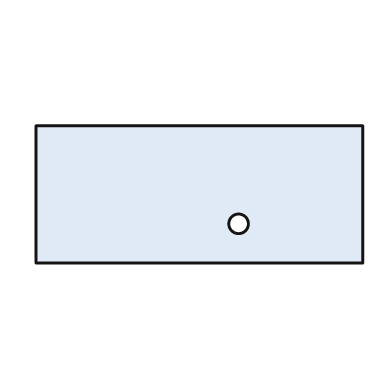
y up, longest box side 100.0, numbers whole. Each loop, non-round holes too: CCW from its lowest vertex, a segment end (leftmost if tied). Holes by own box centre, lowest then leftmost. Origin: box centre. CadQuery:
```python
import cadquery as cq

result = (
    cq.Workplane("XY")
    .moveTo(-50.0, -21.0)
    .lineTo(50.0, -21.0)
    .lineTo(50.0, 21.0)
    .lineTo(-50.0, 21.0)
    .close()
    .moveTo(12.0, -9.0)
    .circle(3.0)
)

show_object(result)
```